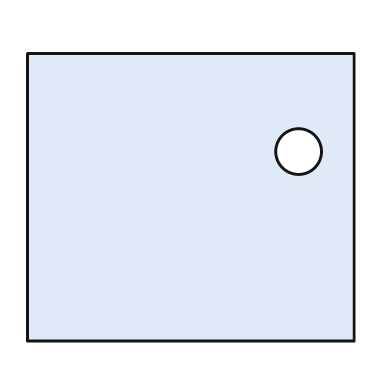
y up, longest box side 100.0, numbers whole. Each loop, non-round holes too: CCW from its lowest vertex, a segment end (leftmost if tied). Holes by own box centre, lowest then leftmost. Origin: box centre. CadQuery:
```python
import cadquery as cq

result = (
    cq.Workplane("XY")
    .moveTo(-50.0, -44.0)
    .lineTo(50.0, -44.0)
    .lineTo(50.0, 44.0)
    .lineTo(-50.0, 44.0)
    .close()
    .moveTo(33.0, 14.0)
    .circle(7.0)
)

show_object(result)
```